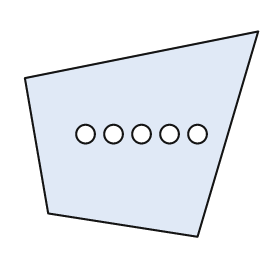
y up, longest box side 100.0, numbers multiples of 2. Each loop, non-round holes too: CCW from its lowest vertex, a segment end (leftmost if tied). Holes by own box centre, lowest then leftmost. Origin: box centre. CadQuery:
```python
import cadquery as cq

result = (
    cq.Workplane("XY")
    .moveTo(24.0, -44.0)
    .lineTo(50.0, 44.0)
    .lineTo(-50.0, 24.0)
    .lineTo(-40.0, -34.0)
    .close()
    .moveTo(-24.0, 0.0)
    .circle(4.0)
    .moveTo(-12.0, 0.0)
    .circle(4.0)
    .moveTo(0.0, 0.0)
    .circle(4.0)
    .moveTo(12.0, 0.0)
    .circle(4.0)
    .moveTo(24.0, 0.0)
    .circle(4.0)
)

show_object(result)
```